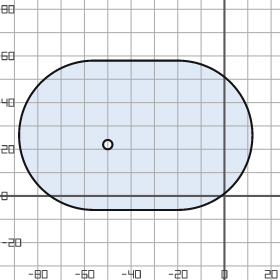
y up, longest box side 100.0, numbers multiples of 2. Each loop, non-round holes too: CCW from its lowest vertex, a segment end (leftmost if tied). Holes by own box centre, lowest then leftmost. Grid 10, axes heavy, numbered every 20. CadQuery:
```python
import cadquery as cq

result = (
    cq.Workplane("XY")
    .moveTo(-56.0, -6.0)
    .lineTo(-20.0, -6.0)
    .threePointArc((12.0, 26.0), (-20.0, 58.0))
    .lineTo(-56.0, 58.0)
    .threePointArc((-88.0, 26.0), (-56.0, -6.0))
    .close()
    .moveTo(-50.0, 22.0)
    .circle(2.0)
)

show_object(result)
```